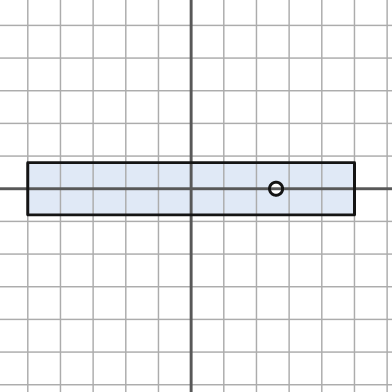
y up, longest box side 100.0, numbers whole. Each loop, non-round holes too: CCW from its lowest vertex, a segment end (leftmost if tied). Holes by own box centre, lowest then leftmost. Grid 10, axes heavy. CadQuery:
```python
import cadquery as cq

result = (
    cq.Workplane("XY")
    .moveTo(-50.0, -8.0)
    .lineTo(50.0, -8.0)
    .lineTo(50.0, 8.0)
    .lineTo(-50.0, 8.0)
    .close()
    .moveTo(26.0, 0.0)
    .circle(2.0)
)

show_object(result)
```